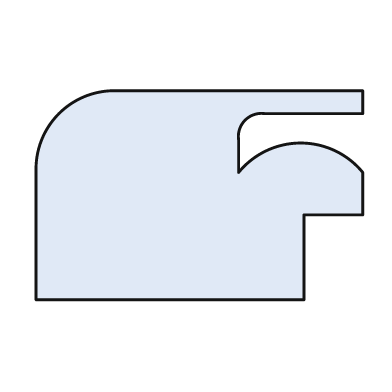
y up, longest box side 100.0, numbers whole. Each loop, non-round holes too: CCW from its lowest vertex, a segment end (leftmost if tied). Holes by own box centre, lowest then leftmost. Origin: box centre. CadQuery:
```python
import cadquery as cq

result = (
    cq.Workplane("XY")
    .moveTo(-50.0, -32.0)
    .lineTo(32.0, -32.0)
    .lineTo(32.0, -6.0)
    .lineTo(50.0, -6.0)
    .lineTo(50.0, 7.0)
    .threePointArc((31.0, 16.0), (12.0, 7.0))
    .lineTo(12.0, 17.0)
    .threePointArc((14.0, 23.0), (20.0, 25.0))
    .lineTo(50.0, 25.0)
    .lineTo(50.0, 32.0)
    .lineTo(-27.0, 32.0)
    .threePointArc((-43.0, 25.0), (-50.0, 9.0))
    .close()
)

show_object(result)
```